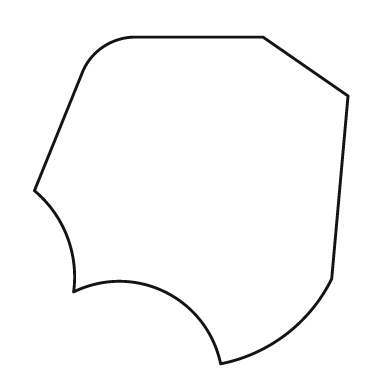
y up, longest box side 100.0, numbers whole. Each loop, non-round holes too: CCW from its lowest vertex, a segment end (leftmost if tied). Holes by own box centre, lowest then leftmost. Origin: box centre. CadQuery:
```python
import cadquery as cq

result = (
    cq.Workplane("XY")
    .moveTo(9.0, -50.0)
    .threePointArc((29.0, -41.0), (43.0, -24.0))
    .lineTo(48.0, 32.0)
    .lineTo(22.0, 50.0)
    .lineTo(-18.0, 50.0)
    .threePointArc((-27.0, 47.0), (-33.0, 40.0))
    .lineTo(-48.0, 3.0)
    .threePointArc((-38.0, -11.0), (-36.0, -28.0))
    .threePointArc((-8.0, -28.0), (9.0, -50.0))
    .close()
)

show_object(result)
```